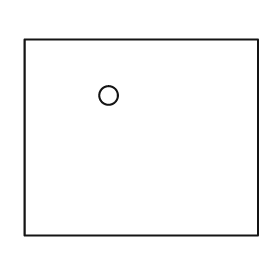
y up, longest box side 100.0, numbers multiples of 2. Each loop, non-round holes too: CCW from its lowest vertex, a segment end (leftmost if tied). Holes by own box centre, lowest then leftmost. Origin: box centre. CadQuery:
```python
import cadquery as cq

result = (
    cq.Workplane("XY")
    .moveTo(-50.0, -42.0)
    .lineTo(50.0, -42.0)
    .lineTo(50.0, 42.0)
    .lineTo(-50.0, 42.0)
    .close()
    .moveTo(-14.0, 18.0)
    .circle(4.0)
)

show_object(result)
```